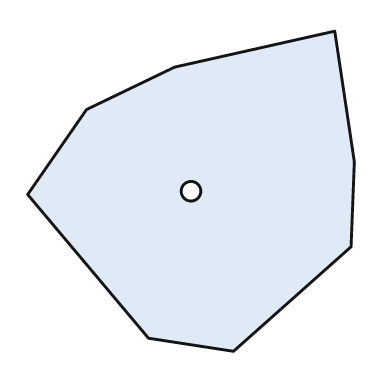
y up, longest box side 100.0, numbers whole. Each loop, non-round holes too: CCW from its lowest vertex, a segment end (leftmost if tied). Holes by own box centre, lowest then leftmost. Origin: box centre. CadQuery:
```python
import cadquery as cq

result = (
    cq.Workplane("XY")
    .moveTo(13.0, -49.0)
    .lineTo(49.0, -17.0)
    .lineTo(50.0, 9.0)
    .lineTo(44.0, 49.0)
    .lineTo(-5.0, 38.0)
    .lineTo(-32.0, 25.0)
    .lineTo(-50.0, -1.0)
    .lineTo(-13.0, -45.0)
    .close()
    .moveTo(0.0, 0.0)
    .circle(3.0)
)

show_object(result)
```